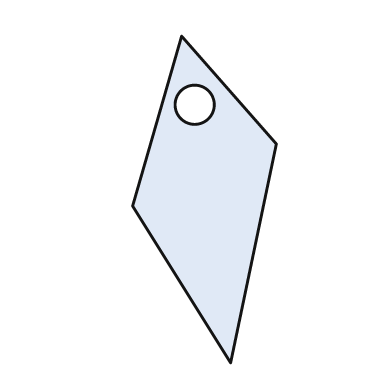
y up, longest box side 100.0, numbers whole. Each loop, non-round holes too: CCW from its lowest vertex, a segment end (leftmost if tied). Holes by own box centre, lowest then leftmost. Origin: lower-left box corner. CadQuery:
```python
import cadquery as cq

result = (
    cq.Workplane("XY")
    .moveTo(30.0, 0.0)
    .lineTo(44.0, 67.0)
    .lineTo(15.0, 100.0)
    .lineTo(0.0, 48.0)
    .close()
    .moveTo(19.0, 79.0)
    .circle(6.0)
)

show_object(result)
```